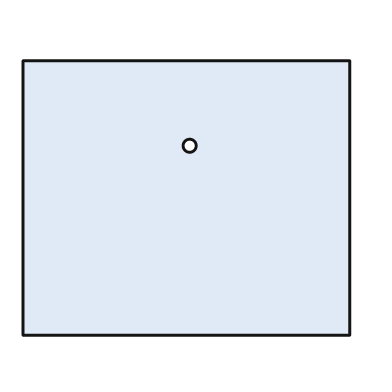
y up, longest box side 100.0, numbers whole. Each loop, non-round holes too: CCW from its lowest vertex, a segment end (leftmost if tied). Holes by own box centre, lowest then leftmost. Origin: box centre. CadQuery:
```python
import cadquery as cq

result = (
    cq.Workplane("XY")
    .moveTo(-50.0, -42.0)
    .lineTo(50.0, -42.0)
    .lineTo(50.0, 42.0)
    .lineTo(-50.0, 42.0)
    .close()
    .moveTo(1.0, 16.0)
    .circle(2.0)
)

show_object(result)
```